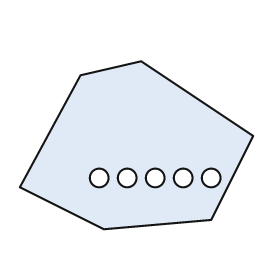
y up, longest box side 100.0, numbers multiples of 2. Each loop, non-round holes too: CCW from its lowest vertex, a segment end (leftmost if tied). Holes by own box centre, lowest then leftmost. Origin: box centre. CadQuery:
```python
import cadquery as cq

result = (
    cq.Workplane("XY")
    .moveTo(-14.0, -36.0)
    .lineTo(32.0, -32.0)
    .lineTo(50.0, 4.0)
    .lineTo(2.0, 36.0)
    .lineTo(-24.0, 30.0)
    .lineTo(-50.0, -18.0)
    .close()
    .moveTo(-16.0, -14.0)
    .circle(4.0)
    .moveTo(-4.0, -14.0)
    .circle(4.0)
    .moveTo(8.0, -14.0)
    .circle(4.0)
    .moveTo(20.0, -14.0)
    .circle(4.0)
    .moveTo(32.0, -14.0)
    .circle(4.0)
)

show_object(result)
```